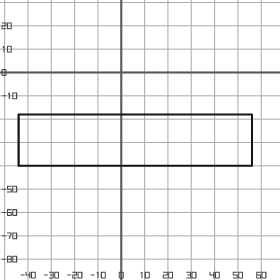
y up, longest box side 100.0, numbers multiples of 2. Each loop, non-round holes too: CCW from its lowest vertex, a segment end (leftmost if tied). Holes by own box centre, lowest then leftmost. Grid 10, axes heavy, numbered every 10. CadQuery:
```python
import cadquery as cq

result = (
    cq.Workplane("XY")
    .moveTo(-44.0, -40.0)
    .lineTo(56.0, -40.0)
    .lineTo(56.0, -18.0)
    .lineTo(-44.0, -18.0)
    .close()
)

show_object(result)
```